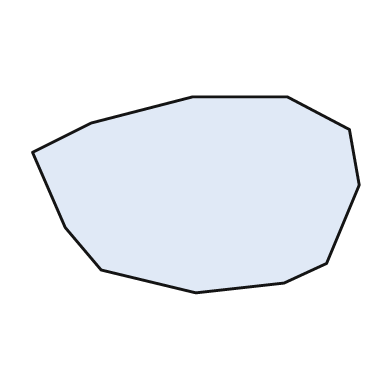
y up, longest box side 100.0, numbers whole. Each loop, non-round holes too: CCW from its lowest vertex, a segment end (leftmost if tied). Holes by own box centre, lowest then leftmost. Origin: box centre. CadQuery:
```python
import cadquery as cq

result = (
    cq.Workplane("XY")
    .moveTo(0.0, -30.0)
    .lineTo(27.0, -27.0)
    .lineTo(40.0, -21.0)
    .lineTo(50.0, 3.0)
    .lineTo(47.0, 20.0)
    .lineTo(28.0, 30.0)
    .lineTo(-1.0, 30.0)
    .lineTo(-32.0, 22.0)
    .lineTo(-50.0, 13.0)
    .lineTo(-40.0, -10.0)
    .lineTo(-29.0, -23.0)
    .close()
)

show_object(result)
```